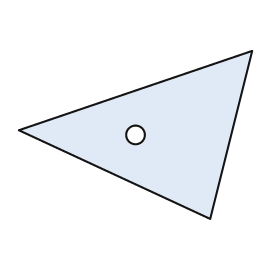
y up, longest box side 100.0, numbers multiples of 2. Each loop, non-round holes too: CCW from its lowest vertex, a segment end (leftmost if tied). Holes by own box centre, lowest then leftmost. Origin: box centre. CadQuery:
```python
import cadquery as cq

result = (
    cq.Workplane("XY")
    .moveTo(32.0, -36.0)
    .lineTo(50.0, 36.0)
    .lineTo(-50.0, 2.0)
    .close()
    .moveTo(0.0, 0.0)
    .circle(4.0)
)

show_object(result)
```